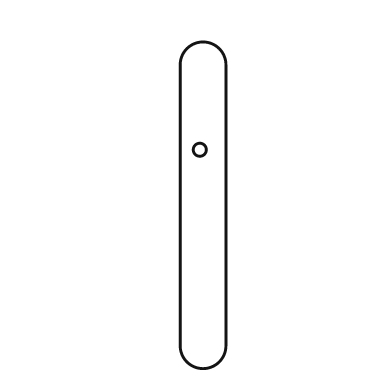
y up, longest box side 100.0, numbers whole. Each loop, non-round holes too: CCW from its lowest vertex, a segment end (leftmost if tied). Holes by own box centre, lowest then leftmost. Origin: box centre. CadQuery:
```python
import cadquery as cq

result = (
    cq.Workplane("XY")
    .moveTo(-7.0, -43.0)
    .threePointArc((0.0, -50.0), (7.0, -43.0))
    .lineTo(7.0, 43.0)
    .threePointArc((0.0, 50.0), (-7.0, 43.0))
    .close()
    .moveTo(-1.0, 17.0)
    .circle(2.0)
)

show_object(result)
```